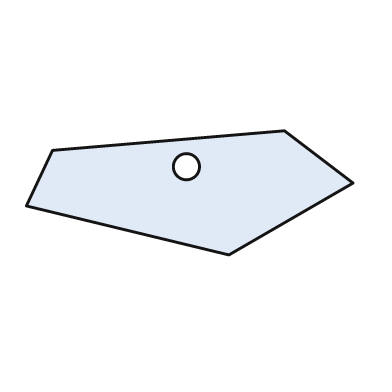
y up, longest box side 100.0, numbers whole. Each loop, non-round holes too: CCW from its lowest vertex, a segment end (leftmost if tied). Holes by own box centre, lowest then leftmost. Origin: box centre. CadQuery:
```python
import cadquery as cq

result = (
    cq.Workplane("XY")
    .moveTo(12.0, -19.0)
    .lineTo(50.0, 3.0)
    .lineTo(29.0, 19.0)
    .lineTo(-42.0, 13.0)
    .lineTo(-50.0, -4.0)
    .close()
    .moveTo(-1.0, 8.0)
    .circle(4.0)
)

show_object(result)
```